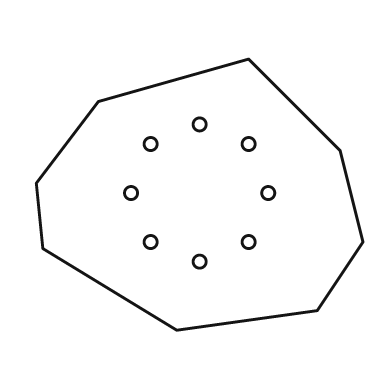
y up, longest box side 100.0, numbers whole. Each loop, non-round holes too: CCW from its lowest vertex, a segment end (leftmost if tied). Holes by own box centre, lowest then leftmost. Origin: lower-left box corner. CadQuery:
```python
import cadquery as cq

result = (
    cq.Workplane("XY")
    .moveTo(43.0, 0.0)
    .lineTo(86.0, 6.0)
    .lineTo(100.0, 27.0)
    .lineTo(93.0, 55.0)
    .lineTo(65.0, 83.0)
    .lineTo(19.0, 70.0)
    .lineTo(0.0, 45.0)
    .lineTo(2.0, 25.0)
    .close()
    .moveTo(50.0, 21.0)
    .circle(2.0)
    .moveTo(35.0, 27.0)
    .circle(2.0)
    .moveTo(65.0, 27.0)
    .circle(2.0)
    .moveTo(29.0, 42.0)
    .circle(2.0)
    .moveTo(71.0, 42.0)
    .circle(2.0)
    .moveTo(35.0, 57.0)
    .circle(2.0)
    .moveTo(65.0, 57.0)
    .circle(2.0)
    .moveTo(50.0, 63.0)
    .circle(2.0)
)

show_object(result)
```